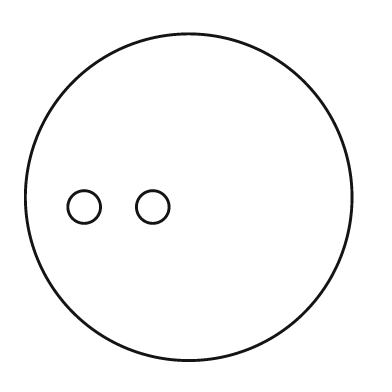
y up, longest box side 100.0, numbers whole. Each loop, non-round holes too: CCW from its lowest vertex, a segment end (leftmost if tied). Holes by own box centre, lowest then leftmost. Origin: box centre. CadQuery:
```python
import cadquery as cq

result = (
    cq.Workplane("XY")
    .moveTo(0.0, 0.0)
    .circle(50.0)
    .moveTo(-32.0, -3.0)
    .circle(5.0)
    .moveTo(-11.0, -3.0)
    .circle(5.0)
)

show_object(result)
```